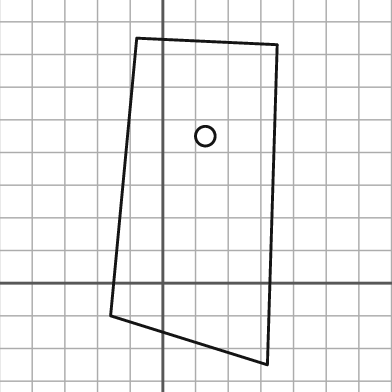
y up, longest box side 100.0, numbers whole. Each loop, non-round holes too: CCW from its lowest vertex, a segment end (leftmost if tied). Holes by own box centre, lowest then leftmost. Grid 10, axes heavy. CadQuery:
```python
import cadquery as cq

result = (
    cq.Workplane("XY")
    .moveTo(32.0, -25.0)
    .lineTo(35.0, 73.0)
    .lineTo(-8.0, 75.0)
    .lineTo(-16.0, -10.0)
    .close()
    .moveTo(13.0, 45.0)
    .circle(3.0)
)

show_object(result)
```